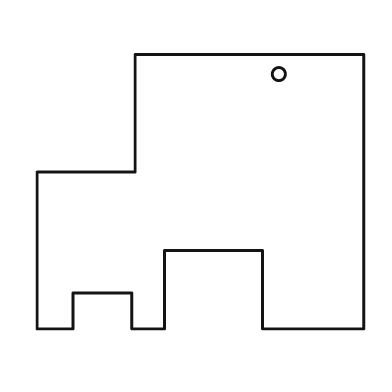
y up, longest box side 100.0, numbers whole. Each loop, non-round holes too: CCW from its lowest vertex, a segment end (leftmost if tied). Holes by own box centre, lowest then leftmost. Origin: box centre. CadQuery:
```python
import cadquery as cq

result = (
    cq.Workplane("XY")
    .moveTo(-50.0, -42.0)
    .lineTo(-39.0, -42.0)
    .lineTo(-39.0, -31.0)
    .lineTo(-21.0, -31.0)
    .lineTo(-21.0, -42.0)
    .lineTo(-11.0, -42.0)
    .lineTo(-11.0, -18.0)
    .lineTo(19.0, -18.0)
    .lineTo(19.0, -42.0)
    .lineTo(50.0, -42.0)
    .lineTo(50.0, 42.0)
    .lineTo(-20.0, 42.0)
    .lineTo(-20.0, 6.0)
    .lineTo(-50.0, 6.0)
    .close()
    .moveTo(24.0, 36.0)
    .circle(2.0)
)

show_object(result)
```